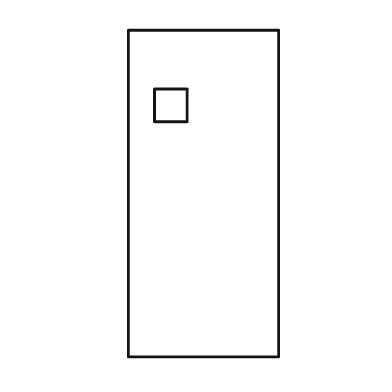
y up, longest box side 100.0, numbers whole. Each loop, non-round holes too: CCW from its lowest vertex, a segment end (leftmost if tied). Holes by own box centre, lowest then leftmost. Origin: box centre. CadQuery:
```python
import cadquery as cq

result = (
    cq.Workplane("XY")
    .moveTo(-23.0, -50.0)
    .lineTo(23.0, -50.0)
    .lineTo(23.0, 50.0)
    .lineTo(-23.0, 50.0)
    .close()
    .moveTo(-15.0, 22.0)
    .lineTo(-5.0, 22.0)
    .lineTo(-5.0, 32.0)
    .lineTo(-15.0, 32.0)
    .close()
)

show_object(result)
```